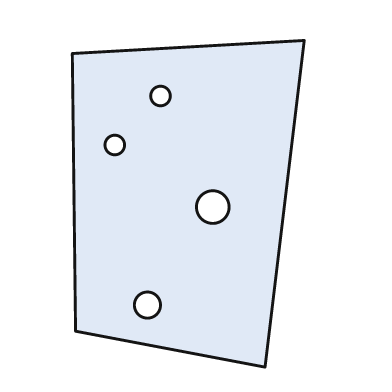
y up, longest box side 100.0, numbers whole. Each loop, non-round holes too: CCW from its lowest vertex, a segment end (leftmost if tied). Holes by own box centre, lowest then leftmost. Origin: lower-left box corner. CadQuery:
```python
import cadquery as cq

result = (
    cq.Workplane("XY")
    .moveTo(59.0, 0.0)
    .lineTo(71.0, 100.0)
    .lineTo(0.0, 96.0)
    .lineTo(1.0, 11.0)
    .close()
    .moveTo(23.0, 19.0)
    .circle(4.0)
    .moveTo(43.0, 49.0)
    .circle(5.0)
    .moveTo(13.0, 68.0)
    .circle(3.0)
    .moveTo(27.0, 83.0)
    .circle(3.0)
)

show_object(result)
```